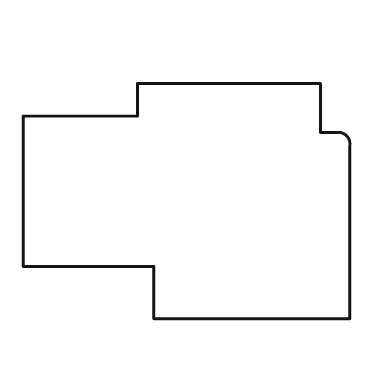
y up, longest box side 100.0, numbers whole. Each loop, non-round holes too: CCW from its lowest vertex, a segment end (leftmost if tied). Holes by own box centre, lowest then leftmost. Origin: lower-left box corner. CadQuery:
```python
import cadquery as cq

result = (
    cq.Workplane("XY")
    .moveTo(40.0, 0.0)
    .lineTo(100.0, 0.0)
    .lineTo(100.0, 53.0)
    .threePointArc((99.0, 56.0), (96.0, 57.0))
    .lineTo(91.0, 57.0)
    .lineTo(91.0, 72.0)
    .lineTo(35.0, 72.0)
    .lineTo(35.0, 62.0)
    .lineTo(0.0, 62.0)
    .lineTo(0.0, 16.0)
    .lineTo(40.0, 16.0)
    .close()
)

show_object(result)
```